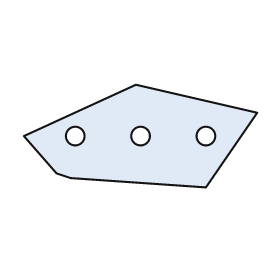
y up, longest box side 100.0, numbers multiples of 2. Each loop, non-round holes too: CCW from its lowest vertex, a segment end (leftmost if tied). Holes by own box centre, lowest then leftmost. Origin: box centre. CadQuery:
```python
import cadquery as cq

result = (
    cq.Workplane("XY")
    .moveTo(28.0, -22.0)
    .lineTo(50.0, 10.0)
    .lineTo(-2.0, 22.0)
    .lineTo(-50.0, 0.0)
    .lineTo(-36.0, -16.0)
    .lineTo(-30.0, -18.0)
    .close()
    .moveTo(-28.0, 0.0)
    .circle(4.0)
    .moveTo(0.0, 0.0)
    .circle(4.0)
    .moveTo(28.0, 0.0)
    .circle(4.0)
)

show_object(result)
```